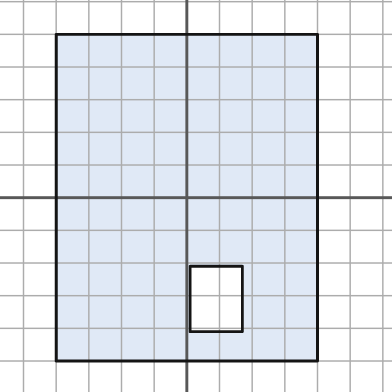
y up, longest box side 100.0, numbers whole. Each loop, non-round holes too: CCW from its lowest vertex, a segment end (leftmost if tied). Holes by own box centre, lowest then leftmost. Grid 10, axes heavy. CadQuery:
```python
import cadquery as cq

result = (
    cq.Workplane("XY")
    .moveTo(-40.0, -50.0)
    .lineTo(40.0, -50.0)
    .lineTo(40.0, 50.0)
    .lineTo(-40.0, 50.0)
    .close()
    .moveTo(1.0, -41.0)
    .lineTo(17.0, -41.0)
    .lineTo(17.0, -21.0)
    .lineTo(1.0, -21.0)
    .close()
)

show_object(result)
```